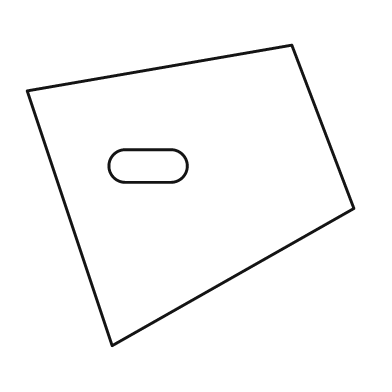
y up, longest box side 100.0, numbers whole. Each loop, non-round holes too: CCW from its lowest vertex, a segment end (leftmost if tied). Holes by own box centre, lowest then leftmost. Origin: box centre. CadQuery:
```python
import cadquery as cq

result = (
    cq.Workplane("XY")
    .moveTo(-24.0, -46.0)
    .lineTo(50.0, -4.0)
    .lineTo(31.0, 46.0)
    .lineTo(-50.0, 32.0)
    .close()
    .moveTo(-20.0, 4.0)
    .lineTo(-6.0, 4.0)
    .threePointArc((-1.0, 9.0), (-6.0, 14.0))
    .lineTo(-20.0, 14.0)
    .threePointArc((-25.0, 9.0), (-20.0, 4.0))
    .close()
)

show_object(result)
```